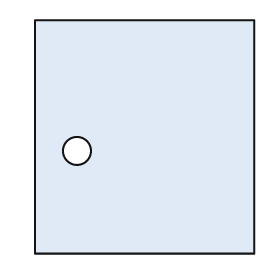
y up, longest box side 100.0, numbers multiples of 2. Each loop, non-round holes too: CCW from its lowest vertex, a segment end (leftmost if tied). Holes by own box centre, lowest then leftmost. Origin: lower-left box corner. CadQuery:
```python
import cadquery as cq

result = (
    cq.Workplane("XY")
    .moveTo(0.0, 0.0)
    .lineTo(94.0, 0.0)
    .lineTo(94.0, 100.0)
    .lineTo(0.0, 100.0)
    .close()
    .moveTo(18.0, 44.0)
    .circle(6.0)
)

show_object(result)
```